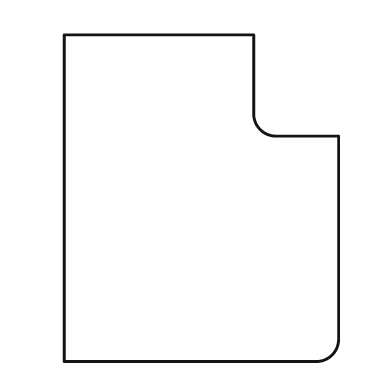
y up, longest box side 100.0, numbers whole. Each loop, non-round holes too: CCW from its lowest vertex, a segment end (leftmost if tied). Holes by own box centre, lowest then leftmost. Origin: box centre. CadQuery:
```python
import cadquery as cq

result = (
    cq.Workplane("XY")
    .moveTo(-42.0, -50.0)
    .lineTo(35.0, -50.0)
    .threePointArc((40.0, -48.0), (42.0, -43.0))
    .lineTo(42.0, 19.0)
    .lineTo(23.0, 19.0)
    .threePointArc((18.0, 21.0), (16.0, 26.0))
    .lineTo(16.0, 50.0)
    .lineTo(-42.0, 50.0)
    .close()
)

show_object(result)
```